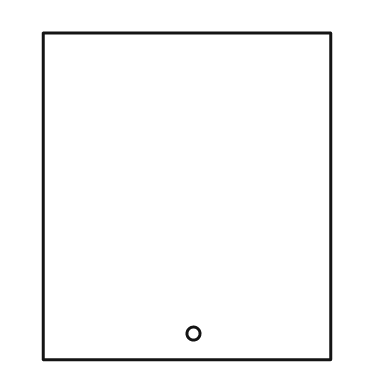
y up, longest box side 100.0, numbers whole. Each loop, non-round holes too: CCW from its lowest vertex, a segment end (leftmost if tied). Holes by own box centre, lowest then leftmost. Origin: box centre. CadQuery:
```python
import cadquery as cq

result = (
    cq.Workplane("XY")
    .moveTo(-44.0, -50.0)
    .lineTo(44.0, -50.0)
    .lineTo(44.0, 50.0)
    .lineTo(-44.0, 50.0)
    .close()
    .moveTo(2.0, -42.0)
    .circle(2.0)
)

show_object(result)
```